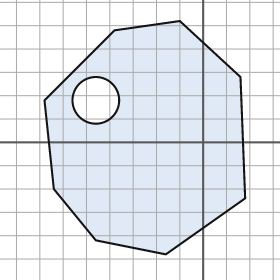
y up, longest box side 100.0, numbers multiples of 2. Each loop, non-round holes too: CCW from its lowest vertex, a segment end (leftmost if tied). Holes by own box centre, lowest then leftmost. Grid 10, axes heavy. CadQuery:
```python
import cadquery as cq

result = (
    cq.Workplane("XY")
    .moveTo(-16.0, -48.0)
    .lineTo(18.0, -24.0)
    .lineTo(16.0, 28.0)
    .lineTo(-10.0, 52.0)
    .lineTo(-38.0, 48.0)
    .lineTo(-68.0, 18.0)
    .lineTo(-64.0, -20.0)
    .lineTo(-46.0, -42.0)
    .close()
    .moveTo(-46.0, 18.0)
    .circle(10.0)
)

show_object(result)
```